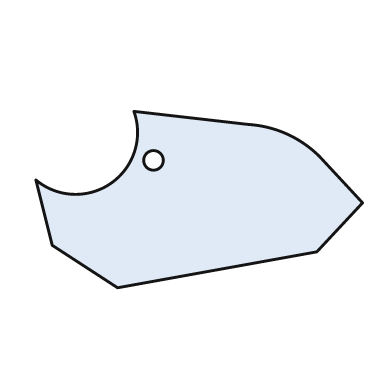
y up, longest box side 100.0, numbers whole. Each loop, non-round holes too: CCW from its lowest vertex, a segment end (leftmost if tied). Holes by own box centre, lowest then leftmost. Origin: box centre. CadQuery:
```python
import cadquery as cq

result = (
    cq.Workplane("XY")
    .moveTo(-25.0, -27.0)
    .lineTo(36.0, -16.0)
    .lineTo(50.0, -1.0)
    .lineTo(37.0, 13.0)
    .threePointArc((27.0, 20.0), (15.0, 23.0))
    .lineTo(-20.0, 27.0)
    .threePointArc((-27.0, 5.0), (-50.0, 6.0))
    .lineTo(-45.0, -14.0)
    .close()
    .moveTo(-14.0, 12.0)
    .circle(3.0)
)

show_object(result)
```